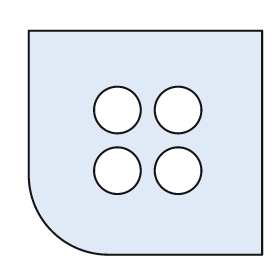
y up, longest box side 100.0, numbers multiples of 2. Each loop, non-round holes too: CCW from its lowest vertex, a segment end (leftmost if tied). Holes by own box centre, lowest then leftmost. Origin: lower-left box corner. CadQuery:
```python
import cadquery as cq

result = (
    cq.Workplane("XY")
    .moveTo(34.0, 0.0)
    .lineTo(100.0, 0.0)
    .lineTo(100.0, 96.0)
    .lineTo(0.0, 96.0)
    .lineTo(0.0, 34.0)
    .threePointArc((10.0, 10.0), (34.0, 0.0))
    .close()
    .moveTo(38.0, 36.0)
    .circle(10.0)
    .moveTo(64.0, 36.0)
    .circle(10.0)
    .moveTo(38.0, 62.0)
    .circle(10.0)
    .moveTo(64.0, 62.0)
    .circle(10.0)
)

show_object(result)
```